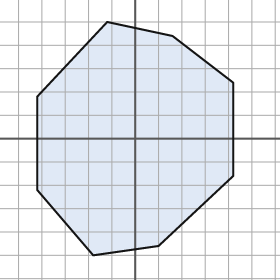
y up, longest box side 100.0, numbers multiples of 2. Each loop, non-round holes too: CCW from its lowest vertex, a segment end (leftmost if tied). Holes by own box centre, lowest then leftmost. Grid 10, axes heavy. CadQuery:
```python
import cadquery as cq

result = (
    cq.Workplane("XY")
    .moveTo(-18.0, -50.0)
    .lineTo(10.0, -46.0)
    .lineTo(42.0, -16.0)
    .lineTo(42.0, 24.0)
    .lineTo(16.0, 44.0)
    .lineTo(-12.0, 50.0)
    .lineTo(-42.0, 18.0)
    .lineTo(-42.0, -22.0)
    .close()
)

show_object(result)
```